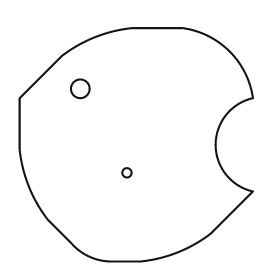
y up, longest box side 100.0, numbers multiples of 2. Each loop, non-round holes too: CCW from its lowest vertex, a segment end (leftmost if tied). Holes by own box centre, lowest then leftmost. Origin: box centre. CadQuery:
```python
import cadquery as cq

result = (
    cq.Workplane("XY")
    .moveTo(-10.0, -50.0)
    .lineTo(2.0, -50.0)
    .threePointArc((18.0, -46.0), (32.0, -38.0))
    .lineTo(50.0, -20.0)
    .threePointArc((34.0, 0.0), (50.0, 20.0))
    .threePointArc((40.0, 40.0), (20.0, 50.0))
    .lineTo(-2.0, 50.0)
    .threePointArc((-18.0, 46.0), (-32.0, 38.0))
    .lineTo(-50.0, 20.0)
    .lineTo(-50.0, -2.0)
    .threePointArc((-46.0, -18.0), (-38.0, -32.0))
    .lineTo(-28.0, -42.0)
    .threePointArc((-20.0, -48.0), (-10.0, -50.0))
    .close()
    .moveTo(-4.0, -12.0)
    .circle(2.0)
    .moveTo(-24.0, 24.0)
    .circle(4.0)
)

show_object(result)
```